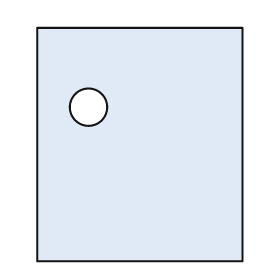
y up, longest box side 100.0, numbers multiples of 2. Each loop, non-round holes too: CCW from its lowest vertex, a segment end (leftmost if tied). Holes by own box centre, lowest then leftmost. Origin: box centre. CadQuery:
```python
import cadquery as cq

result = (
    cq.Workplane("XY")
    .moveTo(-44.0, -50.0)
    .lineTo(44.0, -50.0)
    .lineTo(44.0, 50.0)
    .lineTo(-44.0, 50.0)
    .close()
    .moveTo(-22.0, 16.0)
    .circle(8.0)
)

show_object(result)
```